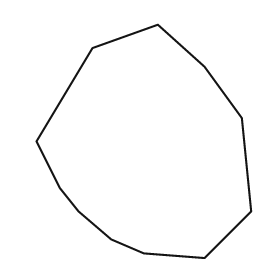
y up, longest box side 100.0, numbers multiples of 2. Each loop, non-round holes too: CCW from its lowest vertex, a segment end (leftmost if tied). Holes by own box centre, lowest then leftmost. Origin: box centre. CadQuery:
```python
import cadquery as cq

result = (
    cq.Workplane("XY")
    .moveTo(26.0, -50.0)
    .lineTo(46.0, -30.0)
    .lineTo(42.0, 10.0)
    .lineTo(26.0, 32.0)
    .lineTo(6.0, 50.0)
    .lineTo(-22.0, 40.0)
    .lineTo(-46.0, 0.0)
    .lineTo(-36.0, -20.0)
    .lineTo(-28.0, -30.0)
    .lineTo(-14.0, -42.0)
    .lineTo(0.0, -48.0)
    .close()
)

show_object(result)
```